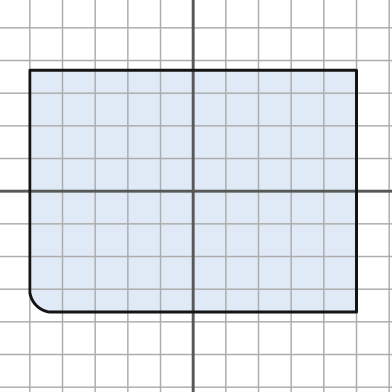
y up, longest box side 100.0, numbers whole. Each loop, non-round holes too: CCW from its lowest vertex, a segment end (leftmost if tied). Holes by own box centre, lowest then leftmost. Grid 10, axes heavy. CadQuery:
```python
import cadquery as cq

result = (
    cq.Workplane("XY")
    .moveTo(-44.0, -37.0)
    .lineTo(50.0, -37.0)
    .lineTo(50.0, 37.0)
    .lineTo(-50.0, 37.0)
    .lineTo(-50.0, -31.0)
    .threePointArc((-48.0, -35.0), (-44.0, -37.0))
    .close()
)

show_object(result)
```